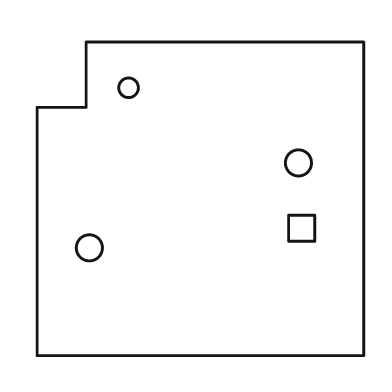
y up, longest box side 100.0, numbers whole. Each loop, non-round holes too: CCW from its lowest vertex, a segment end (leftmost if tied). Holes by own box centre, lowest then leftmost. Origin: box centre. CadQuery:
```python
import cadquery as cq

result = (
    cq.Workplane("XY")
    .moveTo(-50.0, -48.0)
    .lineTo(50.0, -48.0)
    .lineTo(50.0, 48.0)
    .lineTo(-35.0, 48.0)
    .lineTo(-35.0, 28.0)
    .lineTo(-50.0, 28.0)
    .close()
    .moveTo(-34.0, -15.0)
    .circle(4.0)
    .moveTo(27.0, -13.0)
    .lineTo(35.0, -13.0)
    .lineTo(35.0, -5.0)
    .lineTo(27.0, -5.0)
    .close()
    .moveTo(30.0, 11.0)
    .circle(4.0)
    .moveTo(-22.0, 34.0)
    .circle(3.0)
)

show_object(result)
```